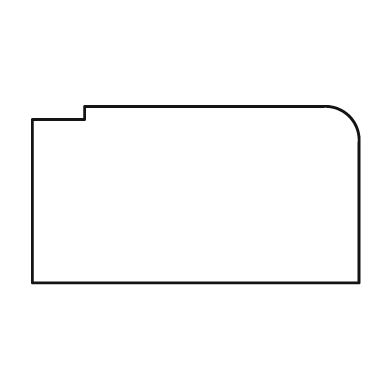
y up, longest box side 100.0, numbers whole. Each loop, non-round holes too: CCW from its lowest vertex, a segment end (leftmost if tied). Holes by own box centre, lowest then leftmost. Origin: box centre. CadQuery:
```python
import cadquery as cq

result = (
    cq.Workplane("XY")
    .moveTo(-50.0, -27.0)
    .lineTo(50.0, -27.0)
    .lineTo(50.0, 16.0)
    .threePointArc((47.0, 24.0), (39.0, 27.0))
    .lineTo(-34.0, 27.0)
    .lineTo(-34.0, 23.0)
    .lineTo(-50.0, 23.0)
    .close()
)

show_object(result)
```